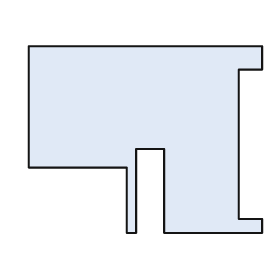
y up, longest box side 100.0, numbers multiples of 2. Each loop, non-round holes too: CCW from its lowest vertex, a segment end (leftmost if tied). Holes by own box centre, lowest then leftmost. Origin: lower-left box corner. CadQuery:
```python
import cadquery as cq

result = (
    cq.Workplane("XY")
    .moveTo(42.0, 0.0)
    .lineTo(46.0, 0.0)
    .lineTo(46.0, 36.0)
    .lineTo(58.0, 36.0)
    .lineTo(58.0, 0.0)
    .lineTo(100.0, 0.0)
    .lineTo(100.0, 6.0)
    .lineTo(90.0, 6.0)
    .lineTo(90.0, 70.0)
    .lineTo(100.0, 70.0)
    .lineTo(100.0, 80.0)
    .lineTo(0.0, 80.0)
    .lineTo(0.0, 28.0)
    .lineTo(42.0, 28.0)
    .close()
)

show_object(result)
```